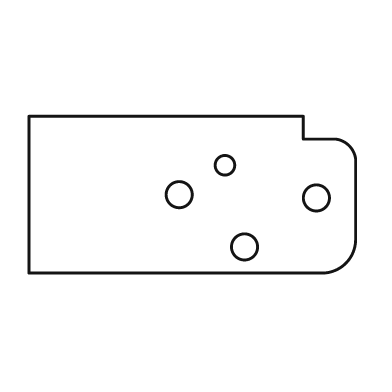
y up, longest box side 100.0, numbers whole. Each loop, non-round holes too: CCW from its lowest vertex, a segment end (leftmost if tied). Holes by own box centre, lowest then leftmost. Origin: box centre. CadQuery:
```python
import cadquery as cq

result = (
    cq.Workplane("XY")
    .moveTo(-50.0, -24.0)
    .lineTo(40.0, -24.0)
    .threePointArc((47.0, -21.0), (50.0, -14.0))
    .lineTo(50.0, 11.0)
    .threePointArc((48.0, 15.0), (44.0, 17.0))
    .lineTo(34.0, 17.0)
    .lineTo(34.0, 24.0)
    .lineTo(-50.0, 24.0)
    .close()
    .moveTo(16.0, -16.0)
    .circle(4.0)
    .moveTo(38.0, -1.0)
    .circle(4.0)
    .moveTo(-4.0, 0.0)
    .circle(4.0)
    .moveTo(10.0, 9.0)
    .circle(3.0)
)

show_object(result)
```